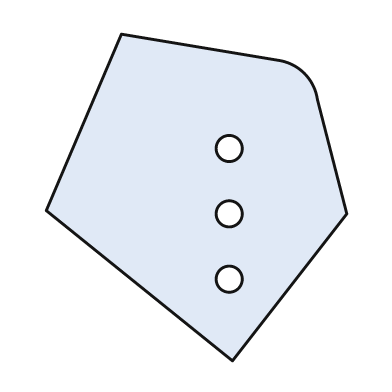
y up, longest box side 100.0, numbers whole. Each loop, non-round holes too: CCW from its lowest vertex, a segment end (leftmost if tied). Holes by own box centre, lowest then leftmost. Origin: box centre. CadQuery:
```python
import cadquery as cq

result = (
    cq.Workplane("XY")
    .moveTo(11.0, -50.0)
    .lineTo(46.0, -5.0)
    .lineTo(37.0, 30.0)
    .threePointArc((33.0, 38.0), (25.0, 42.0))
    .lineTo(-23.0, 50.0)
    .lineTo(-46.0, -4.0)
    .close()
    .moveTo(10.0, -25.0)
    .circle(4.0)
    .moveTo(10.0, -5.0)
    .circle(4.0)
    .moveTo(10.0, 15.0)
    .circle(4.0)
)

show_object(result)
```